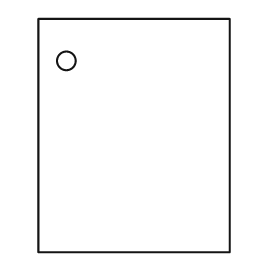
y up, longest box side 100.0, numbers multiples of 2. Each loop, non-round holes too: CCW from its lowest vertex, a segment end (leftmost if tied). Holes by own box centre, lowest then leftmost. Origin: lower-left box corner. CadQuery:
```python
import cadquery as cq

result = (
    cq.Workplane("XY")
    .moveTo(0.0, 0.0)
    .lineTo(82.0, 0.0)
    .lineTo(82.0, 100.0)
    .lineTo(0.0, 100.0)
    .close()
    .moveTo(12.0, 82.0)
    .circle(4.0)
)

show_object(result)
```